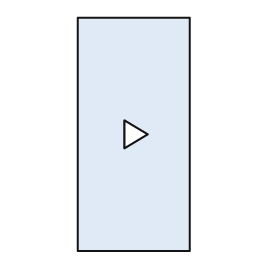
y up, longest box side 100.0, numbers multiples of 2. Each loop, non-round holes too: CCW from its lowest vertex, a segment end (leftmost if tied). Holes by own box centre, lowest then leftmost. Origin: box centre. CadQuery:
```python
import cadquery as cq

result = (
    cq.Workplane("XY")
    .moveTo(-24.0, -50.0)
    .lineTo(24.0, -50.0)
    .lineTo(24.0, 50.0)
    .lineTo(-24.0, 50.0)
    .close()
    .moveTo(-4.0, -6.0)
    .lineTo(6.0, 0.0)
    .lineTo(-4.0, 6.0)
    .close()
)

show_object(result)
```